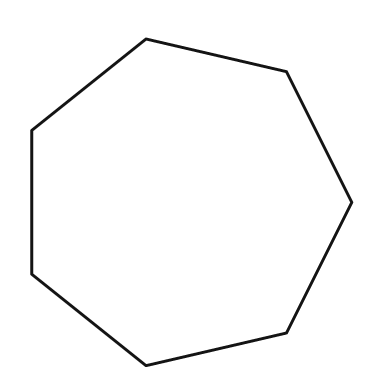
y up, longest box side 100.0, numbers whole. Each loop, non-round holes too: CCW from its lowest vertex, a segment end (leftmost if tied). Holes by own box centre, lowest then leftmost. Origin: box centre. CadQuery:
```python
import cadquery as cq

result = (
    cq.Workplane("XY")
    .moveTo(-14.0, -50.0)
    .lineTo(29.0, -40.0)
    .lineTo(49.0, 0.0)
    .lineTo(29.0, 40.0)
    .lineTo(-14.0, 50.0)
    .lineTo(-49.0, 22.0)
    .lineTo(-49.0, -22.0)
    .close()
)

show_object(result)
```